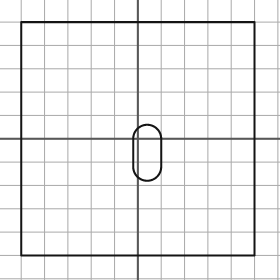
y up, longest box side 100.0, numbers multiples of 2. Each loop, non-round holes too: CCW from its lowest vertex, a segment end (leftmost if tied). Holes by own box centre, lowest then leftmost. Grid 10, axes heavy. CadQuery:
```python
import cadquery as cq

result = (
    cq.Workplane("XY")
    .moveTo(-50.0, -50.0)
    .lineTo(50.0, -50.0)
    .lineTo(50.0, 50.0)
    .lineTo(-50.0, 50.0)
    .close()
    .moveTo(-2.0, -12.0)
    .threePointArc((4.0, -18.0), (10.0, -12.0))
    .lineTo(10.0, 0.0)
    .threePointArc((4.0, 6.0), (-2.0, 0.0))
    .close()
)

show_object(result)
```